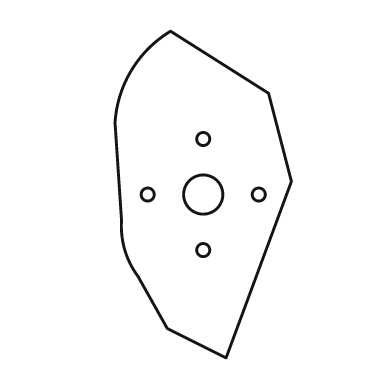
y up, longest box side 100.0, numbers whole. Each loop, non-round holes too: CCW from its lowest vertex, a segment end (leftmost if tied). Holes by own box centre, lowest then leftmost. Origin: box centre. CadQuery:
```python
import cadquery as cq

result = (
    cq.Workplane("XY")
    .moveTo(7.0, -50.0)
    .lineTo(27.0, 4.0)
    .lineTo(20.0, 31.0)
    .lineTo(-10.0, 50.0)
    .threePointArc((-22.0, 38.0), (-27.0, 22.0))
    .lineTo(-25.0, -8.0)
    .threePointArc((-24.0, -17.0), (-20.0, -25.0))
    .lineTo(-11.0, -41.0)
    .close()
    .moveTo(0.0, -17.0)
    .circle(2.0)
    .moveTo(-17.0, 0.0)
    .circle(2.0)
    .moveTo(0.0, 0.0)
    .circle(6.0)
    .moveTo(17.0, 0.0)
    .circle(2.0)
    .moveTo(0.0, 17.0)
    .circle(2.0)
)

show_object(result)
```